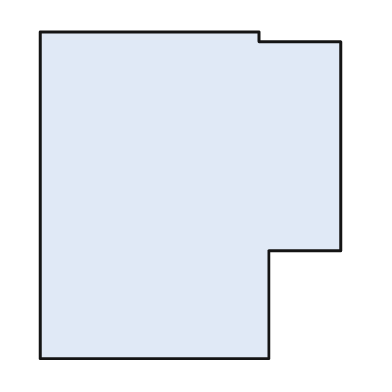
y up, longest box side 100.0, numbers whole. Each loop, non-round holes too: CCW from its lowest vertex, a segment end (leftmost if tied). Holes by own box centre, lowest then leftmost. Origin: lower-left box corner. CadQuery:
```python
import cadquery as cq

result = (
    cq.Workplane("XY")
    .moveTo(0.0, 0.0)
    .lineTo(70.0, 0.0)
    .lineTo(70.0, 33.0)
    .lineTo(92.0, 33.0)
    .lineTo(92.0, 97.0)
    .lineTo(67.0, 97.0)
    .lineTo(67.0, 100.0)
    .lineTo(0.0, 100.0)
    .close()
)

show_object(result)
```